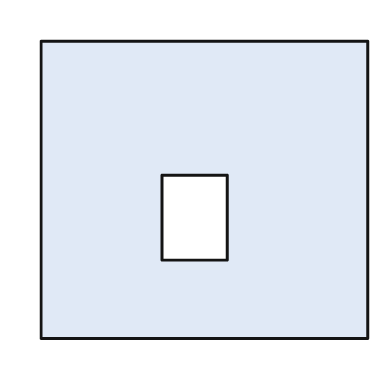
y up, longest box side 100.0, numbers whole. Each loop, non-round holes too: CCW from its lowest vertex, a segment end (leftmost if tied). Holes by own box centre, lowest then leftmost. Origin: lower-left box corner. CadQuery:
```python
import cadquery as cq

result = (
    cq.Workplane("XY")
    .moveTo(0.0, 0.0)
    .lineTo(100.0, 0.0)
    .lineTo(100.0, 91.0)
    .lineTo(0.0, 91.0)
    .close()
    .moveTo(37.0, 24.0)
    .lineTo(57.0, 24.0)
    .lineTo(57.0, 50.0)
    .lineTo(37.0, 50.0)
    .close()
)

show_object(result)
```